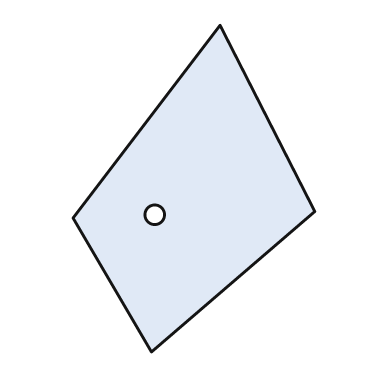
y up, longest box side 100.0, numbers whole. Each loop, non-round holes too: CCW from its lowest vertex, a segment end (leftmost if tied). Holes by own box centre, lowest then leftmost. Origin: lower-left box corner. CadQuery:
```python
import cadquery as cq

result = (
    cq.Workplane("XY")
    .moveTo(24.0, 0.0)
    .lineTo(74.0, 43.0)
    .lineTo(45.0, 100.0)
    .lineTo(0.0, 41.0)
    .close()
    .moveTo(25.0, 42.0)
    .circle(3.0)
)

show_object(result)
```